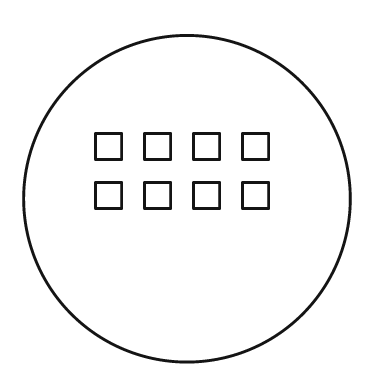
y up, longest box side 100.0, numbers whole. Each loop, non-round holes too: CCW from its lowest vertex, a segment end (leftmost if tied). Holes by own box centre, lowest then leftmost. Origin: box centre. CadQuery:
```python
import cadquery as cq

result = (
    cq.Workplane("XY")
    .moveTo(0.0, 0.0)
    .circle(50.0)
    .moveTo(-28.0, -3.0)
    .lineTo(-20.0, -3.0)
    .lineTo(-20.0, 5.0)
    .lineTo(-28.0, 5.0)
    .close()
    .moveTo(-13.0, -3.0)
    .lineTo(-5.0, -3.0)
    .lineTo(-5.0, 5.0)
    .lineTo(-13.0, 5.0)
    .close()
    .moveTo(2.0, -3.0)
    .lineTo(10.0, -3.0)
    .lineTo(10.0, 5.0)
    .lineTo(2.0, 5.0)
    .close()
    .moveTo(17.0, -3.0)
    .lineTo(25.0, -3.0)
    .lineTo(25.0, 5.0)
    .lineTo(17.0, 5.0)
    .close()
    .moveTo(-28.0, 12.0)
    .lineTo(-20.0, 12.0)
    .lineTo(-20.0, 20.0)
    .lineTo(-28.0, 20.0)
    .close()
    .moveTo(-13.0, 12.0)
    .lineTo(-5.0, 12.0)
    .lineTo(-5.0, 20.0)
    .lineTo(-13.0, 20.0)
    .close()
    .moveTo(2.0, 12.0)
    .lineTo(10.0, 12.0)
    .lineTo(10.0, 20.0)
    .lineTo(2.0, 20.0)
    .close()
    .moveTo(17.0, 12.0)
    .lineTo(25.0, 12.0)
    .lineTo(25.0, 20.0)
    .lineTo(17.0, 20.0)
    .close()
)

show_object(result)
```